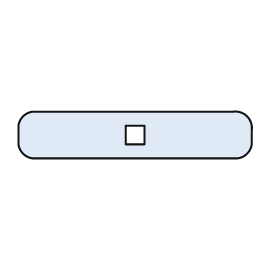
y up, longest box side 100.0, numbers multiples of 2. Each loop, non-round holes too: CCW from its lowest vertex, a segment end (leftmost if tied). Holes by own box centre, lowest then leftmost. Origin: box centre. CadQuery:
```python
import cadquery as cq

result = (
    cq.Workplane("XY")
    .moveTo(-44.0, -10.0)
    .lineTo(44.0, -10.0)
    .threePointArc((48.0, -8.0), (50.0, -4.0))
    .lineTo(50.0, 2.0)
    .threePointArc((48.0, 8.0), (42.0, 10.0))
    .lineTo(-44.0, 10.0)
    .threePointArc((-48.0, 8.0), (-50.0, 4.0))
    .lineTo(-50.0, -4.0)
    .threePointArc((-48.0, -8.0), (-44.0, -10.0))
    .close()
    .moveTo(-4.0, -4.0)
    .lineTo(4.0, -4.0)
    .lineTo(4.0, 4.0)
    .lineTo(-4.0, 4.0)
    .close()
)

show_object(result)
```